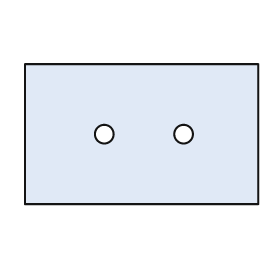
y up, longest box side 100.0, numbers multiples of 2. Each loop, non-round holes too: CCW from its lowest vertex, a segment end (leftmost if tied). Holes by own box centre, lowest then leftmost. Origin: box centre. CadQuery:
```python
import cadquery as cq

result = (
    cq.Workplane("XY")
    .moveTo(-50.0, -30.0)
    .lineTo(50.0, -30.0)
    .lineTo(50.0, 30.0)
    .lineTo(-50.0, 30.0)
    .close()
    .moveTo(-16.0, 0.0)
    .circle(4.0)
    .moveTo(18.0, 0.0)
    .circle(4.0)
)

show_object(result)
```